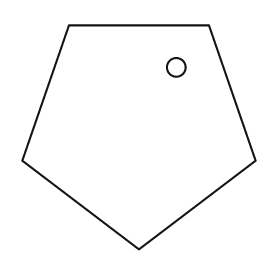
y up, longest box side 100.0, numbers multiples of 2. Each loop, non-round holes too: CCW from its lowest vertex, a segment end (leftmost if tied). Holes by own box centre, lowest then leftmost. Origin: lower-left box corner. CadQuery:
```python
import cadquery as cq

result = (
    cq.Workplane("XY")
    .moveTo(50.0, 0.0)
    .lineTo(100.0, 38.0)
    .lineTo(80.0, 96.0)
    .lineTo(20.0, 96.0)
    .lineTo(0.0, 38.0)
    .close()
    .moveTo(66.0, 78.0)
    .circle(4.0)
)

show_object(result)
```